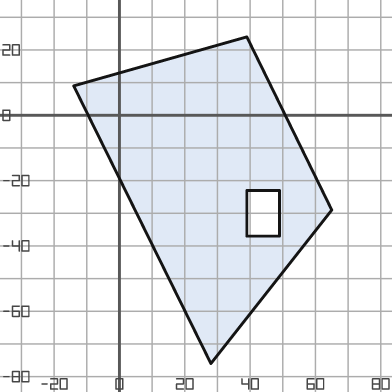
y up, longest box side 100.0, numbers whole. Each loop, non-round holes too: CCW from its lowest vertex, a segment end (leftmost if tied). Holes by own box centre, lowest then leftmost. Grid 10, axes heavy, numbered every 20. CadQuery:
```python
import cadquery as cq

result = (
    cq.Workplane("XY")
    .moveTo(28.0, -76.0)
    .lineTo(65.0, -29.0)
    .lineTo(39.0, 24.0)
    .lineTo(-14.0, 9.0)
    .close()
    .moveTo(39.0, -37.0)
    .lineTo(49.0, -37.0)
    .lineTo(49.0, -23.0)
    .lineTo(39.0, -23.0)
    .close()
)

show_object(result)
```